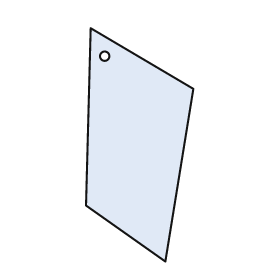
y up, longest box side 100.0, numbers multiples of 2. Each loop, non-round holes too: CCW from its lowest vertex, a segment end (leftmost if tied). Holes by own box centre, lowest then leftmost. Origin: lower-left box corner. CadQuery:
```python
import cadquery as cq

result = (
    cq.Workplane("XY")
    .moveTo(34.0, 0.0)
    .lineTo(46.0, 74.0)
    .lineTo(2.0, 100.0)
    .lineTo(0.0, 24.0)
    .close()
    .moveTo(8.0, 88.0)
    .circle(2.0)
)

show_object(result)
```